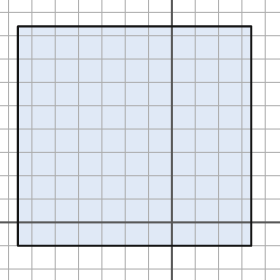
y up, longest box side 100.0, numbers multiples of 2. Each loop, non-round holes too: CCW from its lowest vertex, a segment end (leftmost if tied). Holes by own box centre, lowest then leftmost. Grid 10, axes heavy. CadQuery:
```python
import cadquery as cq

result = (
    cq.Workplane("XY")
    .moveTo(-66.0, -10.0)
    .lineTo(34.0, -10.0)
    .lineTo(34.0, 84.0)
    .lineTo(-66.0, 84.0)
    .close()
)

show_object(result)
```